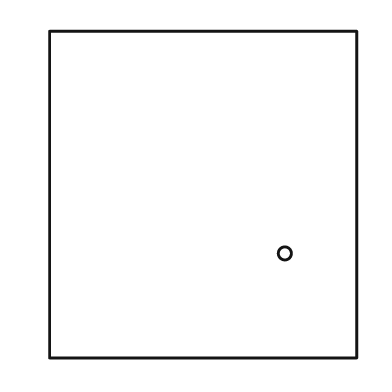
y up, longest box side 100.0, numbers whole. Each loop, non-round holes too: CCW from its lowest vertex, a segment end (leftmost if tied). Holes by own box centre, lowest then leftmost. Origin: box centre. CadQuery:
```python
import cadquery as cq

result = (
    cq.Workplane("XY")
    .moveTo(-47.0, -50.0)
    .lineTo(47.0, -50.0)
    .lineTo(47.0, 50.0)
    .lineTo(-47.0, 50.0)
    .close()
    .moveTo(25.0, -18.0)
    .circle(2.0)
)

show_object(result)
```